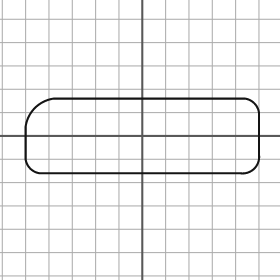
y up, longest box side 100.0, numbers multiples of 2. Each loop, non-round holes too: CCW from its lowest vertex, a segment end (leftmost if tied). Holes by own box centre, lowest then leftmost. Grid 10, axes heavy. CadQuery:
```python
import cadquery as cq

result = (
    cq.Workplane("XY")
    .moveTo(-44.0, -16.0)
    .lineTo(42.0, -16.0)
    .threePointArc((48.0, -14.0), (50.0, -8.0))
    .lineTo(50.0, 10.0)
    .threePointArc((48.0, 14.0), (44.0, 16.0))
    .lineTo(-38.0, 16.0)
    .threePointArc((-46.0, 12.0), (-50.0, 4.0))
    .lineTo(-50.0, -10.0)
    .threePointArc((-48.0, -14.0), (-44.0, -16.0))
    .close()
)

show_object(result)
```